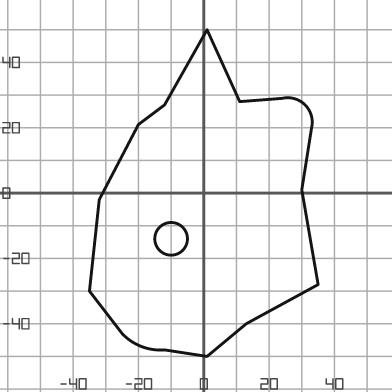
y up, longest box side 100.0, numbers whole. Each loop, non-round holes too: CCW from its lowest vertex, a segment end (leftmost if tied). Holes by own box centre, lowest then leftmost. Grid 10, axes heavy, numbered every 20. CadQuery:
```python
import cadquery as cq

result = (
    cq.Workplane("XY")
    .moveTo(1.0, -50.0)
    .lineTo(13.0, -40.0)
    .lineTo(35.0, -28.0)
    .lineTo(30.0, 1.0)
    .lineTo(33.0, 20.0)
    .threePointArc((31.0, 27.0), (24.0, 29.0))
    .lineTo(11.0, 28.0)
    .lineTo(1.0, 50.0)
    .lineTo(-12.0, 27.0)
    .lineTo(-20.0, 21.0)
    .lineTo(-32.0, -2.0)
    .lineTo(-35.0, -30.0)
    .lineTo(-25.0, -43.0)
    .threePointArc((-19.0, -47.0), (-12.0, -48.0))
    .close()
    .moveTo(-10.0, -14.0)
    .circle(5.0)
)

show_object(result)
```